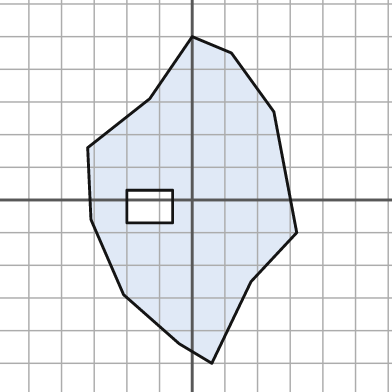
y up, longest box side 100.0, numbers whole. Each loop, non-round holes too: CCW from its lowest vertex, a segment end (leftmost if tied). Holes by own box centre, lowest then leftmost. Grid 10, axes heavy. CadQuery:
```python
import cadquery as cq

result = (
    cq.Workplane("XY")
    .moveTo(6.0, -50.0)
    .lineTo(18.0, -25.0)
    .lineTo(32.0, -10.0)
    .lineTo(25.0, 27.0)
    .lineTo(12.0, 45.0)
    .lineTo(0.0, 50.0)
    .lineTo(-13.0, 31.0)
    .lineTo(-32.0, 16.0)
    .lineTo(-31.0, -6.0)
    .lineTo(-21.0, -29.0)
    .lineTo(-4.0, -44.0)
    .close()
    .moveTo(-20.0, -7.0)
    .lineTo(-6.0, -7.0)
    .lineTo(-6.0, 3.0)
    .lineTo(-20.0, 3.0)
    .close()
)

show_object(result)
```